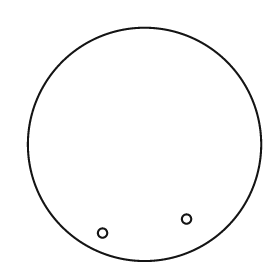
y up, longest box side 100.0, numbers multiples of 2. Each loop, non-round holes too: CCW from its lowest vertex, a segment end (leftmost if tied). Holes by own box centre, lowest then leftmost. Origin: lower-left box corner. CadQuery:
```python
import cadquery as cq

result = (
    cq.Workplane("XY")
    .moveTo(50.0, 50.0)
    .circle(50.0)
    .moveTo(32.0, 12.0)
    .circle(2.0)
    .moveTo(68.0, 18.0)
    .circle(2.0)
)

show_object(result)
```